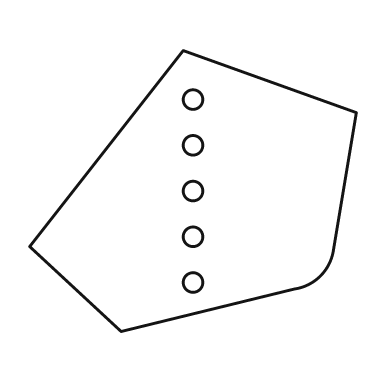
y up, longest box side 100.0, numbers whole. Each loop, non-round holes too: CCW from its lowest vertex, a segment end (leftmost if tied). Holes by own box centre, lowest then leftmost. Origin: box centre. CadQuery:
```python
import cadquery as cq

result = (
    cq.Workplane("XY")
    .moveTo(-22.0, -43.0)
    .lineTo(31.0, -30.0)
    .threePointArc((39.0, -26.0), (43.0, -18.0))
    .lineTo(50.0, 24.0)
    .lineTo(-3.0, 43.0)
    .lineTo(-50.0, -17.0)
    .close()
    .moveTo(0.0, -28.0)
    .circle(3.0)
    .moveTo(0.0, -14.0)
    .circle(3.0)
    .moveTo(0.0, 0.0)
    .circle(3.0)
    .moveTo(0.0, 14.0)
    .circle(3.0)
    .moveTo(0.0, 28.0)
    .circle(3.0)
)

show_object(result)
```